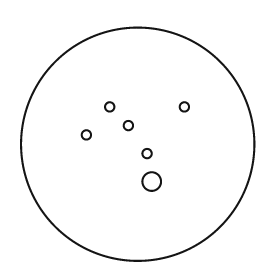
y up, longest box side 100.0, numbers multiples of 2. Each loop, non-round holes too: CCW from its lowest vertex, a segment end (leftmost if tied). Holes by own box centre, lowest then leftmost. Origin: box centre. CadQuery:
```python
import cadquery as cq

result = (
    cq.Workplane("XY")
    .moveTo(0.0, 0.0)
    .circle(50.0)
    .moveTo(6.0, -16.0)
    .circle(4.0)
    .moveTo(4.0, -4.0)
    .circle(2.0)
    .moveTo(-22.0, 4.0)
    .circle(2.0)
    .moveTo(-4.0, 8.0)
    .circle(2.0)
    .moveTo(-12.0, 16.0)
    .circle(2.0)
    .moveTo(20.0, 16.0)
    .circle(2.0)
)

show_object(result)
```